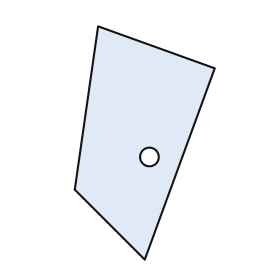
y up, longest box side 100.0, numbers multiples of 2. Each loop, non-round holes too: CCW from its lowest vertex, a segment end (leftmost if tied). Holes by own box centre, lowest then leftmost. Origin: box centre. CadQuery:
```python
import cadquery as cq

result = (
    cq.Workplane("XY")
    .moveTo(0.0, -50.0)
    .lineTo(30.0, 32.0)
    .lineTo(-20.0, 50.0)
    .lineTo(-30.0, -20.0)
    .close()
    .moveTo(2.0, -6.0)
    .circle(4.0)
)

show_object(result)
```